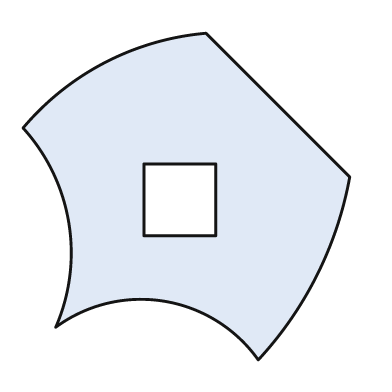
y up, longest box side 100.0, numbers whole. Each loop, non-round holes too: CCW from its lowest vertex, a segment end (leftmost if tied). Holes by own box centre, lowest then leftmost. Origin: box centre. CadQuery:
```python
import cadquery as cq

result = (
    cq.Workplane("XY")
    .moveTo(22.0, -50.0)
    .threePointArc((40.0, -24.0), (50.0, 6.0))
    .lineTo(6.0, 50.0)
    .threePointArc((-25.0, 41.0), (-50.0, 21.0))
    .threePointArc((-36.0, -8.0), (-40.0, -40.0))
    .threePointArc((-7.0, -32.0), (22.0, -50.0))
    .close()
    .moveTo(-13.0, -12.0)
    .lineTo(9.0, -12.0)
    .lineTo(9.0, 10.0)
    .lineTo(-13.0, 10.0)
    .close()
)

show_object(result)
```